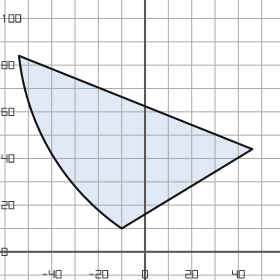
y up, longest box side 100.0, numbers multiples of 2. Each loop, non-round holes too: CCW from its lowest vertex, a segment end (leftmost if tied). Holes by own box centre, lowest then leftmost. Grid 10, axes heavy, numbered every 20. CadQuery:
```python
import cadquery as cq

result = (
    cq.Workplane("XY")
    .moveTo(-10.0, 10.0)
    .lineTo(46.0, 44.0)
    .lineTo(-54.0, 84.0)
    .threePointArc((-40.0, 42.0), (-10.0, 10.0))
    .close()
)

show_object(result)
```